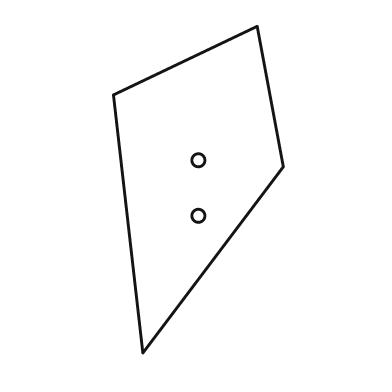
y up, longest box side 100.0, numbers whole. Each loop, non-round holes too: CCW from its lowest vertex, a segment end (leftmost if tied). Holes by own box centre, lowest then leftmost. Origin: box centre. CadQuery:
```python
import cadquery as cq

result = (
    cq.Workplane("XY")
    .moveTo(-17.0, -50.0)
    .lineTo(26.0, 7.0)
    .lineTo(18.0, 50.0)
    .lineTo(-26.0, 29.0)
    .close()
    .moveTo(0.0, -8.0)
    .circle(2.0)
    .moveTo(0.0, 9.0)
    .circle(2.0)
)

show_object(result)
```